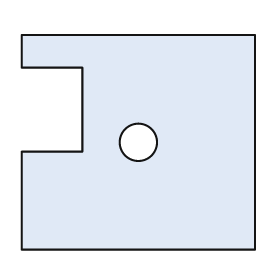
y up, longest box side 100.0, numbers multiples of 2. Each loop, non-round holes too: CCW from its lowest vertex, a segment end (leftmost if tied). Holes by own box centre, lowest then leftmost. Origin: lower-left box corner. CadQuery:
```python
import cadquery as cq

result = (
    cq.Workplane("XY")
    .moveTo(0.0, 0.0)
    .lineTo(100.0, 0.0)
    .lineTo(100.0, 92.0)
    .lineTo(0.0, 92.0)
    .lineTo(0.0, 78.0)
    .lineTo(26.0, 78.0)
    .lineTo(26.0, 42.0)
    .lineTo(0.0, 42.0)
    .close()
    .moveTo(50.0, 46.0)
    .circle(8.0)
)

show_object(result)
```